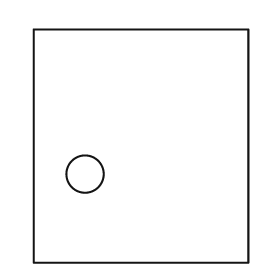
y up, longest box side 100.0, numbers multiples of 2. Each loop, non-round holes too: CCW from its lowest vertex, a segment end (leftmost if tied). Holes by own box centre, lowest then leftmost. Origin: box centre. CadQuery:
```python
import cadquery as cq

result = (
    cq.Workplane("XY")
    .moveTo(-46.0, -50.0)
    .lineTo(46.0, -50.0)
    .lineTo(46.0, 50.0)
    .lineTo(-46.0, 50.0)
    .close()
    .moveTo(-24.0, -12.0)
    .circle(8.0)
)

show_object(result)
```